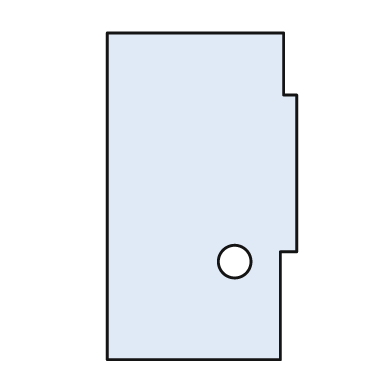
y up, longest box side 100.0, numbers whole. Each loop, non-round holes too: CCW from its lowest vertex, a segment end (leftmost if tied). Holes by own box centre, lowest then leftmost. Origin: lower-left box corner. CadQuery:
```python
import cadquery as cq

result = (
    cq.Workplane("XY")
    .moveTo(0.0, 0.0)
    .lineTo(53.0, 0.0)
    .lineTo(53.0, 33.0)
    .lineTo(58.0, 33.0)
    .lineTo(58.0, 81.0)
    .lineTo(54.0, 81.0)
    .lineTo(54.0, 100.0)
    .lineTo(0.0, 100.0)
    .close()
    .moveTo(39.0, 30.0)
    .circle(5.0)
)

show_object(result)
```